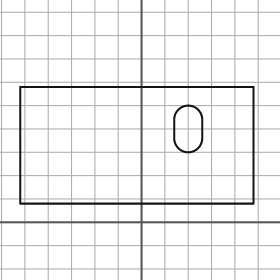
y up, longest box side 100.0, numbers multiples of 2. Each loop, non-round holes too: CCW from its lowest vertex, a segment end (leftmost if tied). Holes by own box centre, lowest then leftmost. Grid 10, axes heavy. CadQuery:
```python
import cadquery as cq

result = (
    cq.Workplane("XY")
    .moveTo(-52.0, 8.0)
    .lineTo(48.0, 8.0)
    .lineTo(48.0, 58.0)
    .lineTo(-52.0, 58.0)
    .close()
    .moveTo(14.0, 36.0)
    .threePointArc((20.0, 30.0), (26.0, 36.0))
    .lineTo(26.0, 44.0)
    .threePointArc((20.0, 50.0), (14.0, 44.0))
    .close()
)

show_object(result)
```